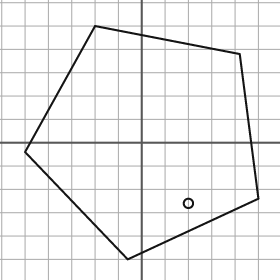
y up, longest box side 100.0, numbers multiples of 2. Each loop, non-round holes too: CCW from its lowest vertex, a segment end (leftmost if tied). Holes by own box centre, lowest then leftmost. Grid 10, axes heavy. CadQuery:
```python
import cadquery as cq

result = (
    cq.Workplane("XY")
    .moveTo(-6.0, -50.0)
    .lineTo(50.0, -24.0)
    .lineTo(42.0, 38.0)
    .lineTo(-20.0, 50.0)
    .lineTo(-50.0, -4.0)
    .close()
    .moveTo(20.0, -26.0)
    .circle(2.0)
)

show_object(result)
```